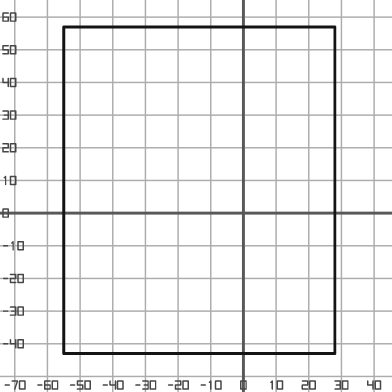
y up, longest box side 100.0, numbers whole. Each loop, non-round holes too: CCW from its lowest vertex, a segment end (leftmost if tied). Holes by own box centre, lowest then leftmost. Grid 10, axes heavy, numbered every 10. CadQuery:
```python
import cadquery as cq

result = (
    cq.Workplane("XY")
    .moveTo(-55.0, -43.0)
    .lineTo(28.0, -43.0)
    .lineTo(28.0, 57.0)
    .lineTo(-55.0, 57.0)
    .close()
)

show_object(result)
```